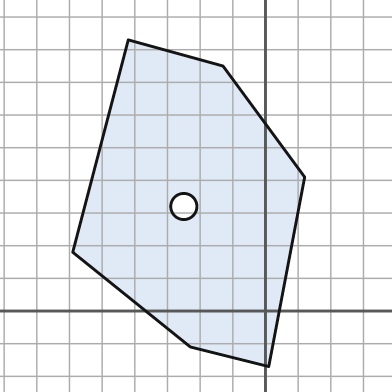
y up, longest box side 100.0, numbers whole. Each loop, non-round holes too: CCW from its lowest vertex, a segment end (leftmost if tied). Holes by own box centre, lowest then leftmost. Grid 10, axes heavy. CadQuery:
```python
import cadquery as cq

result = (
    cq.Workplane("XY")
    .moveTo(1.0, -17.0)
    .lineTo(12.0, 41.0)
    .lineTo(-13.0, 75.0)
    .lineTo(-42.0, 83.0)
    .lineTo(-59.0, 18.0)
    .lineTo(-23.0, -11.0)
    .close()
    .moveTo(-25.0, 32.0)
    .circle(4.0)
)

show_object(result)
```